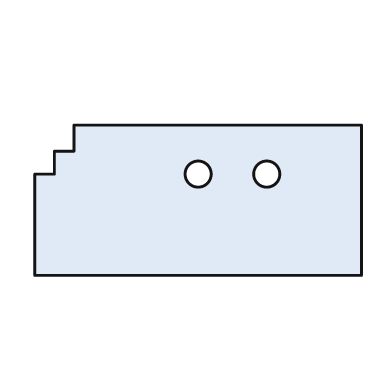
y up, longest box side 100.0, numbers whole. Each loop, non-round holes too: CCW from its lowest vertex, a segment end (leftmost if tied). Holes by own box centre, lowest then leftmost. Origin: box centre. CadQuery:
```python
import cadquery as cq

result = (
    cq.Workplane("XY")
    .moveTo(-50.0, -23.0)
    .lineTo(50.0, -23.0)
    .lineTo(50.0, 23.0)
    .lineTo(-38.0, 23.0)
    .lineTo(-38.0, 15.0)
    .lineTo(-44.0, 15.0)
    .lineTo(-44.0, 8.0)
    .lineTo(-50.0, 8.0)
    .close()
    .moveTo(0.0, 8.0)
    .circle(4.0)
    .moveTo(21.0, 8.0)
    .circle(4.0)
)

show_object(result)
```